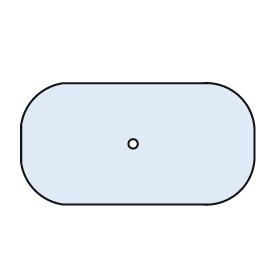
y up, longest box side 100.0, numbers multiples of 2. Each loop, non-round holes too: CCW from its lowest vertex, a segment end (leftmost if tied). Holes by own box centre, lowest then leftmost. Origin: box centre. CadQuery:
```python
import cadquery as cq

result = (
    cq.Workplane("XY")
    .moveTo(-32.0, -26.0)
    .lineTo(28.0, -26.0)
    .threePointArc((44.0, -20.0), (50.0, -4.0))
    .lineTo(50.0, 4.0)
    .threePointArc((44.0, 20.0), (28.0, 26.0))
    .lineTo(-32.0, 26.0)
    .threePointArc((-44.0, 20.0), (-50.0, 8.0))
    .lineTo(-50.0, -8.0)
    .threePointArc((-44.0, -20.0), (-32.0, -26.0))
    .close()
    .moveTo(-2.0, 0.0)
    .circle(2.0)
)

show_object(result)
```